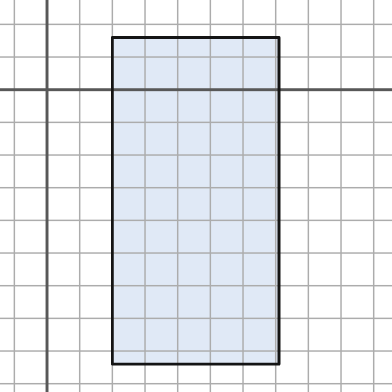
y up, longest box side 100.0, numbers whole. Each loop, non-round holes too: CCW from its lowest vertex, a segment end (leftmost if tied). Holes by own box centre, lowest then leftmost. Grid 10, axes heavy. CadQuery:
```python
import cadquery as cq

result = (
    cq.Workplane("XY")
    .moveTo(20.0, -84.0)
    .lineTo(71.0, -84.0)
    .lineTo(71.0, 16.0)
    .lineTo(20.0, 16.0)
    .close()
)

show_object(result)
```